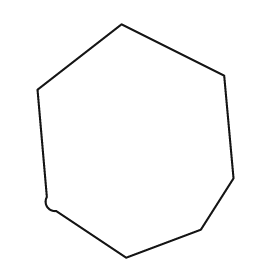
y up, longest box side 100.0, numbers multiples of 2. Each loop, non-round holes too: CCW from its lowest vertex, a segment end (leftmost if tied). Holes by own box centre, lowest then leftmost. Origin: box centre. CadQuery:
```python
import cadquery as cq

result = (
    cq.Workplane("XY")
    .moveTo(-4.0, -50.0)
    .lineTo(28.0, -38.0)
    .lineTo(42.0, -16.0)
    .lineTo(38.0, 28.0)
    .lineTo(-6.0, 50.0)
    .lineTo(-42.0, 22.0)
    .lineTo(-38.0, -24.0)
    .threePointArc((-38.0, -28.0), (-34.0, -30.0))
    .close()
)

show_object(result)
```